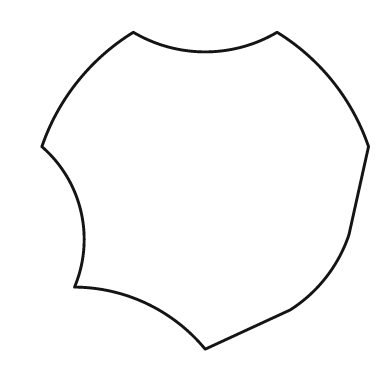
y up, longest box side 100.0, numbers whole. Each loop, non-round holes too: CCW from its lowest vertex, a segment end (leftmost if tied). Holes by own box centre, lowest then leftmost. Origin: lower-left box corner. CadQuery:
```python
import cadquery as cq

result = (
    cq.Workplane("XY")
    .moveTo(50.0, 0.0)
    .lineTo(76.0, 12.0)
    .threePointArc((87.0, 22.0), (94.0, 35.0))
    .lineTo(100.0, 62.0)
    .threePointArc((89.0, 82.0), (72.0, 97.0))
    .threePointArc((50.0, 91.0), (28.0, 97.0))
    .threePointArc((11.0, 82.0), (0.0, 62.0))
    .threePointArc((12.0, 42.0), (10.0, 19.0))
    .threePointArc((32.0, 14.0), (50.0, 0.0))
    .close()
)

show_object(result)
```